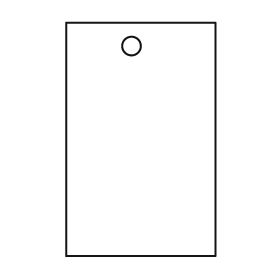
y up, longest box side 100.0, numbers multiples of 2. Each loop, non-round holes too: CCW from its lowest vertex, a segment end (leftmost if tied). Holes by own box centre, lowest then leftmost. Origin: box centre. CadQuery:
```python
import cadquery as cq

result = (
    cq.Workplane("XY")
    .moveTo(-32.0, -50.0)
    .lineTo(32.0, -50.0)
    .lineTo(32.0, 50.0)
    .lineTo(-32.0, 50.0)
    .close()
    .moveTo(-4.0, 40.0)
    .circle(4.0)
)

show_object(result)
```